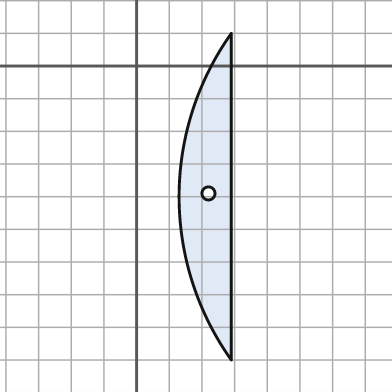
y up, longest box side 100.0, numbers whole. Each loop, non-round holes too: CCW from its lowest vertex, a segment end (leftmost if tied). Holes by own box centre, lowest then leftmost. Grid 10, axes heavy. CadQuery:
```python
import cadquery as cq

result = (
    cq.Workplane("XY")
    .moveTo(29.0, -90.0)
    .lineTo(29.0, 10.0)
    .threePointArc((13.0, -40.0), (29.0, -90.0))
    .close()
    .moveTo(22.0, -39.0)
    .circle(2.0)
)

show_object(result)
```